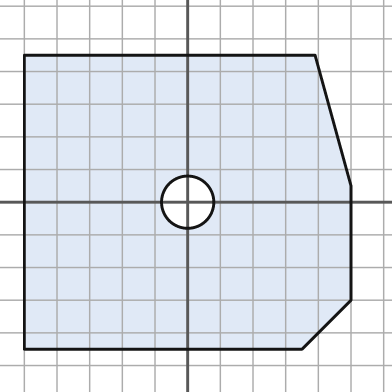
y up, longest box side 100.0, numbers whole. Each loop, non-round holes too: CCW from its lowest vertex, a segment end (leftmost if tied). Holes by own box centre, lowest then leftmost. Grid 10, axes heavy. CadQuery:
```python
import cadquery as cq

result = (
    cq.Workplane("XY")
    .moveTo(-50.0, -45.0)
    .lineTo(35.0, -45.0)
    .lineTo(50.0, -30.0)
    .lineTo(50.0, 5.0)
    .lineTo(39.0, 45.0)
    .lineTo(-50.0, 45.0)
    .close()
    .moveTo(0.0, 0.0)
    .circle(8.0)
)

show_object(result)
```